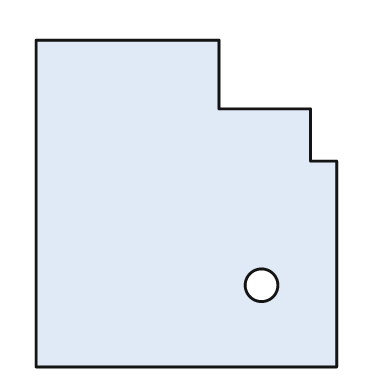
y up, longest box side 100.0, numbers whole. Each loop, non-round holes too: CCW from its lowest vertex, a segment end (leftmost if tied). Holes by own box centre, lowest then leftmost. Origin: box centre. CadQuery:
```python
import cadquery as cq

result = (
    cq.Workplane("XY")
    .moveTo(-46.0, -50.0)
    .lineTo(46.0, -50.0)
    .lineTo(46.0, 13.0)
    .lineTo(38.0, 13.0)
    .lineTo(38.0, 29.0)
    .lineTo(10.0, 29.0)
    .lineTo(10.0, 50.0)
    .lineTo(-46.0, 50.0)
    .close()
    .moveTo(23.0, -25.0)
    .circle(5.0)
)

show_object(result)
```